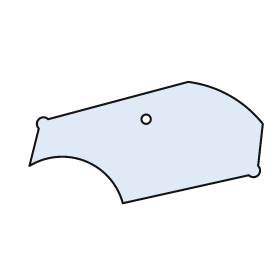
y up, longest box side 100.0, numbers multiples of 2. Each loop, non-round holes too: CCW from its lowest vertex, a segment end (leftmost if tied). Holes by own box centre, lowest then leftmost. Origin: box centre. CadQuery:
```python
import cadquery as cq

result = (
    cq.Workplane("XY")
    .moveTo(-10.0, -26.0)
    .lineTo(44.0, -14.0)
    .threePointArc((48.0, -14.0), (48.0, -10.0))
    .lineTo(50.0, 8.0)
    .threePointArc((36.0, 20.0), (18.0, 26.0))
    .lineTo(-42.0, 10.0)
    .threePointArc((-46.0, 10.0), (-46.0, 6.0))
    .lineTo(-50.0, -10.0)
    .threePointArc((-26.0, -8.0), (-10.0, -26.0))
    .close()
    .moveTo(0.0, 10.0)
    .circle(2.0)
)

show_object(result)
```